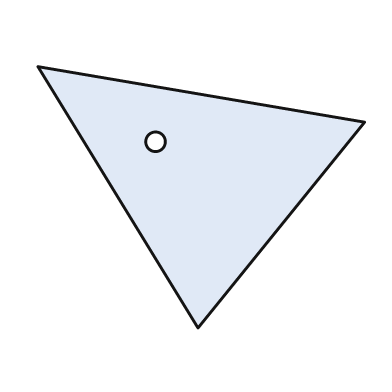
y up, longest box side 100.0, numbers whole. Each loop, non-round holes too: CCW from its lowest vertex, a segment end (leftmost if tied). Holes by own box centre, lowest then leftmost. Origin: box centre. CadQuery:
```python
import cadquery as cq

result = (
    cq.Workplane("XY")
    .moveTo(-1.0, -40.0)
    .lineTo(50.0, 23.0)
    .lineTo(-50.0, 40.0)
    .close()
    .moveTo(-14.0, 17.0)
    .circle(3.0)
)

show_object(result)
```